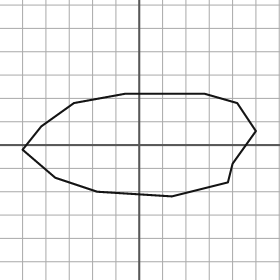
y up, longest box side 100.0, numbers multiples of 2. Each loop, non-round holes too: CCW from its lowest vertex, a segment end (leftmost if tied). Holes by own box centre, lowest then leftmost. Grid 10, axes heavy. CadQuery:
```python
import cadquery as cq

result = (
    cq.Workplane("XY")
    .moveTo(14.0, -22.0)
    .lineTo(38.0, -16.0)
    .lineTo(40.0, -8.0)
    .lineTo(50.0, 6.0)
    .lineTo(42.0, 18.0)
    .lineTo(28.0, 22.0)
    .lineTo(-6.0, 22.0)
    .lineTo(-28.0, 18.0)
    .lineTo(-42.0, 8.0)
    .lineTo(-50.0, -2.0)
    .lineTo(-36.0, -14.0)
    .lineTo(-18.0, -20.0)
    .close()
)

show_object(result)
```